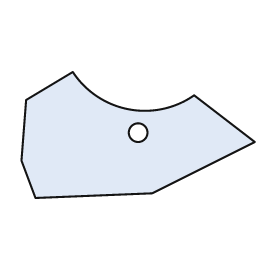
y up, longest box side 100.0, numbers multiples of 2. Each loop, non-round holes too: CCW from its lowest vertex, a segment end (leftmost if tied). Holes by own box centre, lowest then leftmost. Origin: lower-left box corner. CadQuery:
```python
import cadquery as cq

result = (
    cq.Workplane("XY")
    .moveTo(6.0, 0.0)
    .lineTo(56.0, 2.0)
    .lineTo(100.0, 24.0)
    .lineTo(74.0, 44.0)
    .threePointArc((46.0, 38.0), (22.0, 54.0))
    .lineTo(2.0, 42.0)
    .lineTo(0.0, 16.0)
    .close()
    .moveTo(50.0, 28.0)
    .circle(4.0)
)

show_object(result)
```